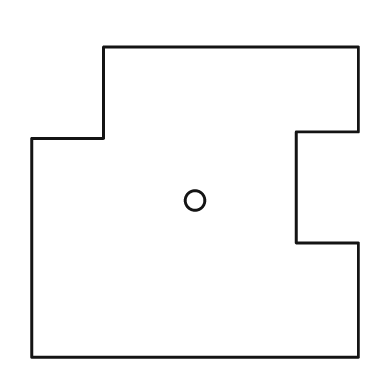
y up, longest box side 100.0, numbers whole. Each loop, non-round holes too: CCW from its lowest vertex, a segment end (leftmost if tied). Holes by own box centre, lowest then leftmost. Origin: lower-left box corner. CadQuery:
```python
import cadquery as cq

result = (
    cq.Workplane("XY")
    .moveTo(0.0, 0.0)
    .lineTo(100.0, 0.0)
    .lineTo(100.0, 35.0)
    .lineTo(81.0, 35.0)
    .lineTo(81.0, 69.0)
    .lineTo(100.0, 69.0)
    .lineTo(100.0, 95.0)
    .lineTo(22.0, 95.0)
    .lineTo(22.0, 67.0)
    .lineTo(0.0, 67.0)
    .close()
    .moveTo(50.0, 48.0)
    .circle(3.0)
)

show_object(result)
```